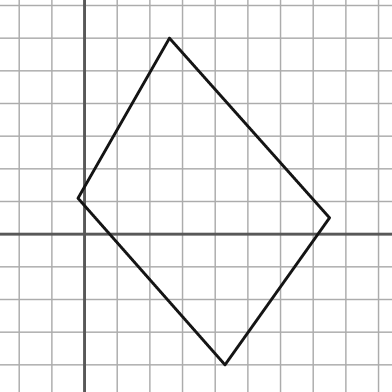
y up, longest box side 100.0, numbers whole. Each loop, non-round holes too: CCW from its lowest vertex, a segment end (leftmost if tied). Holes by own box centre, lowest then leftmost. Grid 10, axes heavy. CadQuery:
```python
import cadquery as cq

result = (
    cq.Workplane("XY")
    .moveTo(43.0, -40.0)
    .lineTo(75.0, 5.0)
    .lineTo(26.0, 60.0)
    .lineTo(-2.0, 11.0)
    .close()
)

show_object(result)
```